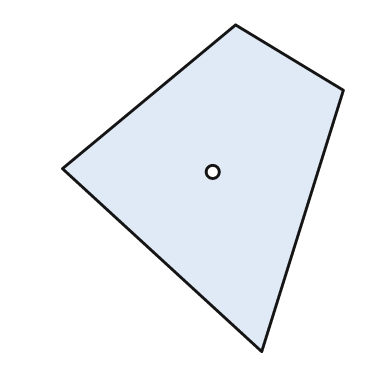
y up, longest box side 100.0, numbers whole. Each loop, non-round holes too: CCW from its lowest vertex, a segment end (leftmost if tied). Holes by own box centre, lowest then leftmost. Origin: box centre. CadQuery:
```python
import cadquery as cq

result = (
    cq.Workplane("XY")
    .moveTo(18.0, -50.0)
    .lineTo(43.0, 30.0)
    .lineTo(10.0, 50.0)
    .lineTo(-43.0, 6.0)
    .close()
    .moveTo(3.0, 5.0)
    .circle(2.0)
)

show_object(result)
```